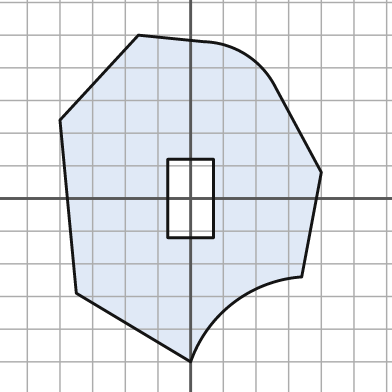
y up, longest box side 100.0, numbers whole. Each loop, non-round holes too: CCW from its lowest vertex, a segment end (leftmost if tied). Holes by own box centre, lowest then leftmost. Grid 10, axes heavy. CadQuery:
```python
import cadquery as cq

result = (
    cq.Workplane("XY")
    .moveTo(0.0, -50.0)
    .threePointArc((13.0, -32.0), (34.0, -24.0))
    .lineTo(40.0, 8.0)
    .lineTo(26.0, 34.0)
    .threePointArc((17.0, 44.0), (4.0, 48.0))
    .lineTo(-16.0, 50.0)
    .lineTo(-40.0, 24.0)
    .lineTo(-35.0, -29.0)
    .close()
    .moveTo(-7.0, -12.0)
    .lineTo(7.0, -12.0)
    .lineTo(7.0, 12.0)
    .lineTo(-7.0, 12.0)
    .close()
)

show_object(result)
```